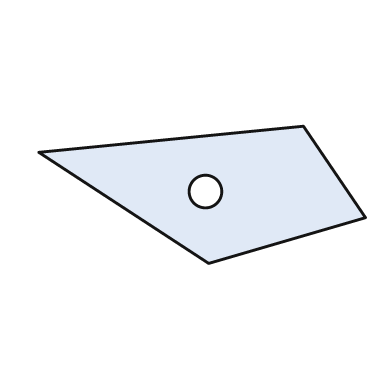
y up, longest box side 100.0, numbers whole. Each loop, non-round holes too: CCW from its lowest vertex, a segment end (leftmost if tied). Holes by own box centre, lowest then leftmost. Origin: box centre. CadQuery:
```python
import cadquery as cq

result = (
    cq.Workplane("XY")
    .moveTo(2.0, -21.0)
    .lineTo(50.0, -7.0)
    .lineTo(31.0, 21.0)
    .lineTo(-50.0, 13.0)
    .close()
    .moveTo(1.0, 1.0)
    .circle(5.0)
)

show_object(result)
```